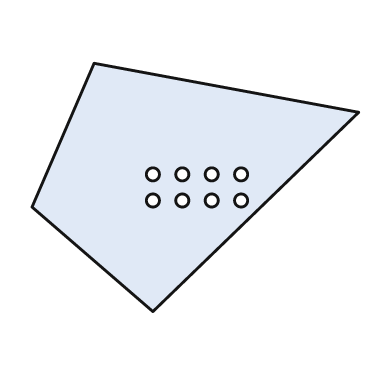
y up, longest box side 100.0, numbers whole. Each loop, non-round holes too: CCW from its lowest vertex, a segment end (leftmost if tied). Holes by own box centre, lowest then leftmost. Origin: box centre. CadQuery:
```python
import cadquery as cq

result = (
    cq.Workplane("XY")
    .moveTo(-13.0, -38.0)
    .lineTo(50.0, 23.0)
    .lineTo(-31.0, 38.0)
    .lineTo(-50.0, -6.0)
    .close()
    .moveTo(-13.0, -4.0)
    .circle(2.0)
    .moveTo(-4.0, -4.0)
    .circle(2.0)
    .moveTo(5.0, -4.0)
    .circle(2.0)
    .moveTo(14.0, -4.0)
    .circle(2.0)
    .moveTo(-13.0, 4.0)
    .circle(2.0)
    .moveTo(-4.0, 4.0)
    .circle(2.0)
    .moveTo(5.0, 4.0)
    .circle(2.0)
    .moveTo(14.0, 4.0)
    .circle(2.0)
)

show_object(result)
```